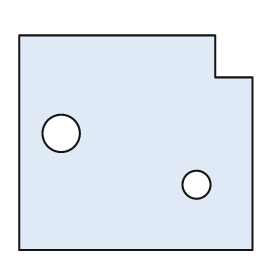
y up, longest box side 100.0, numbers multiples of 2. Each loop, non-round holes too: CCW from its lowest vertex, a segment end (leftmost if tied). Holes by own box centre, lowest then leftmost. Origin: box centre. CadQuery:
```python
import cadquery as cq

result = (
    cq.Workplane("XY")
    .moveTo(-50.0, -46.0)
    .lineTo(50.0, -46.0)
    .lineTo(50.0, 28.0)
    .lineTo(34.0, 28.0)
    .lineTo(34.0, 46.0)
    .lineTo(-50.0, 46.0)
    .close()
    .moveTo(26.0, -18.0)
    .circle(6.0)
    .moveTo(-32.0, 4.0)
    .circle(8.0)
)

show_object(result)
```